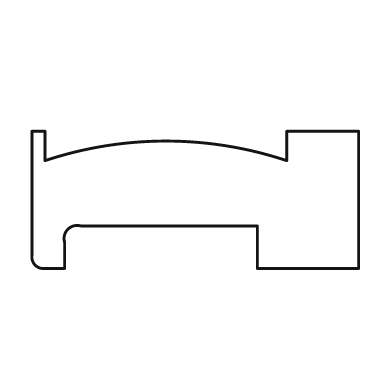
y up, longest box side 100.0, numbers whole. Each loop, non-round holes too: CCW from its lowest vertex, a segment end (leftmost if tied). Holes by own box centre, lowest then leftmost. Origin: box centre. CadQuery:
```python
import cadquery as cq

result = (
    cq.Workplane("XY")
    .moveTo(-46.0, -21.0)
    .lineTo(-40.0, -21.0)
    .lineTo(-40.0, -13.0)
    .threePointArc((-39.0, -9.0), (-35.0, -8.0))
    .lineTo(19.0, -8.0)
    .lineTo(19.0, -21.0)
    .lineTo(50.0, -21.0)
    .lineTo(50.0, 21.0)
    .lineTo(28.0, 21.0)
    .lineTo(28.0, 12.0)
    .threePointArc((-9.0, 18.0), (-46.0, 12.0))
    .lineTo(-46.0, 21.0)
    .lineTo(-50.0, 21.0)
    .lineTo(-50.0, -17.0)
    .threePointArc((-49.0, -20.0), (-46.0, -21.0))
    .close()
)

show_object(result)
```